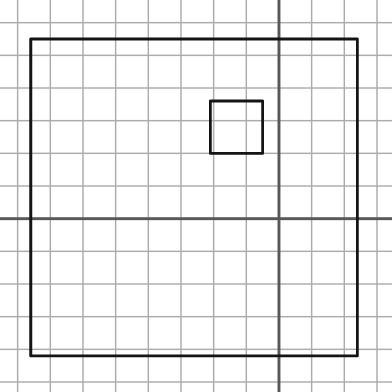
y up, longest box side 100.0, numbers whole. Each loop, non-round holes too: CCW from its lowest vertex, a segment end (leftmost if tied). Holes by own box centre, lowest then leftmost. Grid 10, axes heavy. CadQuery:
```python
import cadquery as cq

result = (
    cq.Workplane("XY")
    .moveTo(-76.0, -42.0)
    .lineTo(24.0, -42.0)
    .lineTo(24.0, 55.0)
    .lineTo(-76.0, 55.0)
    .close()
    .moveTo(-21.0, 20.0)
    .lineTo(-5.0, 20.0)
    .lineTo(-5.0, 36.0)
    .lineTo(-21.0, 36.0)
    .close()
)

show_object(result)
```